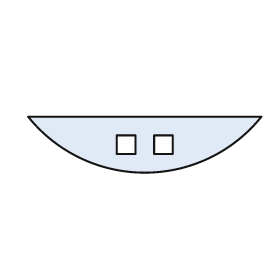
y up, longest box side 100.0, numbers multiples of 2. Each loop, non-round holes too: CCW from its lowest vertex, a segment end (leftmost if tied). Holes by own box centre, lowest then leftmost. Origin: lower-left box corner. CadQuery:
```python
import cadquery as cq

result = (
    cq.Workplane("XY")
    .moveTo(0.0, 24.0)
    .threePointArc((50.0, 0.0), (100.0, 24.0))
    .close()
    .moveTo(38.0, 8.0)
    .lineTo(46.0, 8.0)
    .lineTo(46.0, 16.0)
    .lineTo(38.0, 16.0)
    .close()
    .moveTo(54.0, 8.0)
    .lineTo(62.0, 8.0)
    .lineTo(62.0, 16.0)
    .lineTo(54.0, 16.0)
    .close()
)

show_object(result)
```